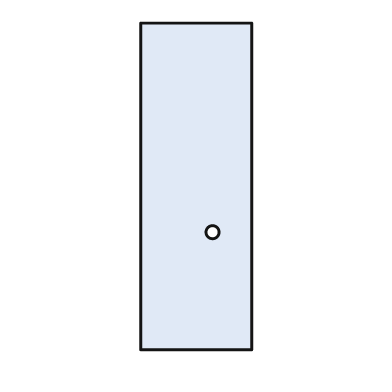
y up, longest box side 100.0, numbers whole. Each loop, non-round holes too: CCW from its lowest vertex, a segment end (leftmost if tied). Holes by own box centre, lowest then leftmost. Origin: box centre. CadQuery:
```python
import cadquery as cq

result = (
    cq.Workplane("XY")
    .moveTo(-17.0, -50.0)
    .lineTo(17.0, -50.0)
    .lineTo(17.0, 50.0)
    .lineTo(-17.0, 50.0)
    .close()
    .moveTo(5.0, -14.0)
    .circle(2.0)
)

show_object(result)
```